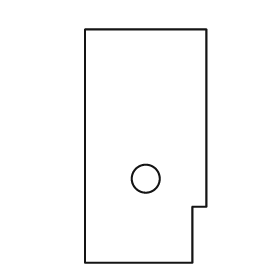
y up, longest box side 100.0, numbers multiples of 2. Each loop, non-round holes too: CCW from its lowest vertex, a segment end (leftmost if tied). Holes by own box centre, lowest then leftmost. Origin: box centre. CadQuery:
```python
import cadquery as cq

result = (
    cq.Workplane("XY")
    .moveTo(-26.0, -50.0)
    .lineTo(20.0, -50.0)
    .lineTo(20.0, -26.0)
    .lineTo(26.0, -26.0)
    .lineTo(26.0, 50.0)
    .lineTo(-26.0, 50.0)
    .close()
    .moveTo(0.0, -14.0)
    .circle(6.0)
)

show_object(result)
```